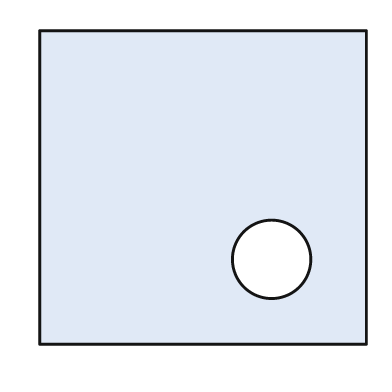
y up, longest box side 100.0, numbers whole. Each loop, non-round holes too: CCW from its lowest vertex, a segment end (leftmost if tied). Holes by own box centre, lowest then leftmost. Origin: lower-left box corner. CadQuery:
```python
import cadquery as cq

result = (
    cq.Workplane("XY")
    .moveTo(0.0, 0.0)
    .lineTo(100.0, 0.0)
    .lineTo(100.0, 96.0)
    .lineTo(0.0, 96.0)
    .close()
    .moveTo(71.0, 26.0)
    .circle(12.0)
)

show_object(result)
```